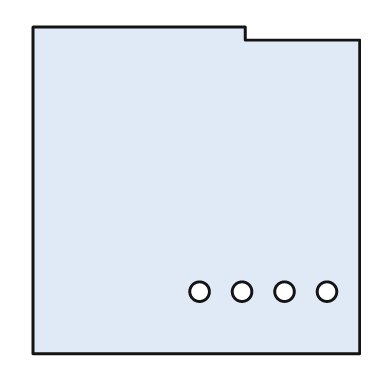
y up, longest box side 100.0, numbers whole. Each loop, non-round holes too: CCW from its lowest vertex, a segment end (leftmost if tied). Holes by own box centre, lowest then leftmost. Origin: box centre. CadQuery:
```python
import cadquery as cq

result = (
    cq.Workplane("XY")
    .moveTo(-50.0, -50.0)
    .lineTo(50.0, -50.0)
    .lineTo(50.0, 46.0)
    .lineTo(15.0, 46.0)
    .lineTo(15.0, 50.0)
    .lineTo(-50.0, 50.0)
    .close()
    .moveTo(1.0, -31.0)
    .circle(3.0)
    .moveTo(14.0, -31.0)
    .circle(3.0)
    .moveTo(27.0, -31.0)
    .circle(3.0)
    .moveTo(40.0, -31.0)
    .circle(3.0)
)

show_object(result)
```